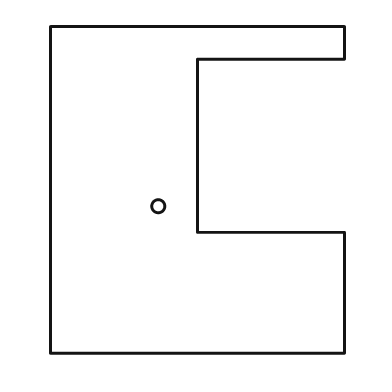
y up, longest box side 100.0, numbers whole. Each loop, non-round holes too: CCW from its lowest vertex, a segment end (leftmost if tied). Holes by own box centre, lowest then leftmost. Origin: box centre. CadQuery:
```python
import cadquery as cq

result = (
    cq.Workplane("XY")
    .moveTo(-45.0, -50.0)
    .lineTo(45.0, -50.0)
    .lineTo(45.0, -13.0)
    .lineTo(0.0, -13.0)
    .lineTo(0.0, 40.0)
    .lineTo(45.0, 40.0)
    .lineTo(45.0, 50.0)
    .lineTo(-45.0, 50.0)
    .close()
    .moveTo(-12.0, -5.0)
    .circle(2.0)
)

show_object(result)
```